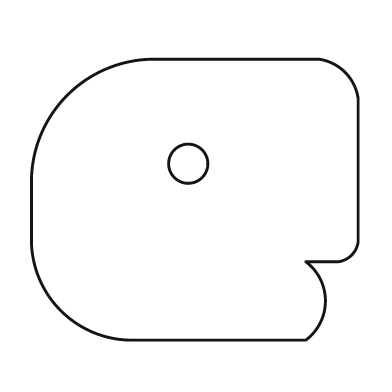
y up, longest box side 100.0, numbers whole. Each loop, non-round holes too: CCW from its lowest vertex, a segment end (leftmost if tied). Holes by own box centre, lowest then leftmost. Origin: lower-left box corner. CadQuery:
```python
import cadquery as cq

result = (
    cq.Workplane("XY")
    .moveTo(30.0, 0.0)
    .lineTo(84.0, 0.0)
    .threePointArc((90.0, 12.0), (84.0, 24.0))
    .lineTo(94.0, 24.0)
    .threePointArc((98.0, 26.0), (100.0, 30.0))
    .lineTo(100.0, 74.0)
    .threePointArc((96.0, 82.0), (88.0, 86.0))
    .lineTo(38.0, 86.0)
    .threePointArc((11.0, 75.0), (0.0, 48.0))
    .lineTo(0.0, 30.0)
    .threePointArc((9.0, 9.0), (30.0, 0.0))
    .close()
    .moveTo(48.0, 54.0)
    .circle(6.0)
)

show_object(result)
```